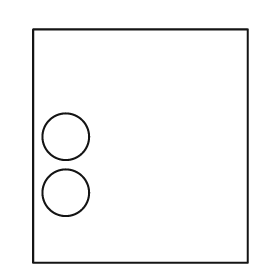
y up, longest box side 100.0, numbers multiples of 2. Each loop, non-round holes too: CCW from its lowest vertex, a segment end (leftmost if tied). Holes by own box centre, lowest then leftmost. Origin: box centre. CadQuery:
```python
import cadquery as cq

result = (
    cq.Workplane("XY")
    .moveTo(-46.0, -50.0)
    .lineTo(46.0, -50.0)
    .lineTo(46.0, 50.0)
    .lineTo(-46.0, 50.0)
    .close()
    .moveTo(-32.0, -20.0)
    .circle(10.0)
    .moveTo(-32.0, 4.0)
    .circle(10.0)
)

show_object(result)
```